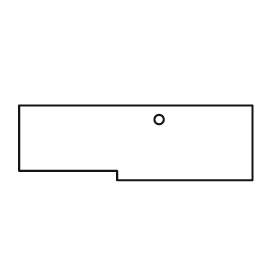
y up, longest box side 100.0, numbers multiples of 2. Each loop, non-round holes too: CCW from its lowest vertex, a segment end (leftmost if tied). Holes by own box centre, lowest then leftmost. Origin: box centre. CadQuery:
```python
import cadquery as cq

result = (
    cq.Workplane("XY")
    .moveTo(-8.0, -16.0)
    .lineTo(50.0, -16.0)
    .lineTo(50.0, 16.0)
    .lineTo(-50.0, 16.0)
    .lineTo(-50.0, -12.0)
    .lineTo(-8.0, -12.0)
    .close()
    .moveTo(10.0, 10.0)
    .circle(2.0)
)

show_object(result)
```